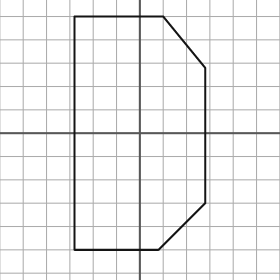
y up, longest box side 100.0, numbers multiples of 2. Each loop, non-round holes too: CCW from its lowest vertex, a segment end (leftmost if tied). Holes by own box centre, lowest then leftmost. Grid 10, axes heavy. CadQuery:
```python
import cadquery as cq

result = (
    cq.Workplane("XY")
    .moveTo(-28.0, -50.0)
    .lineTo(8.0, -50.0)
    .lineTo(28.0, -30.0)
    .lineTo(28.0, 28.0)
    .lineTo(10.0, 50.0)
    .lineTo(-28.0, 50.0)
    .close()
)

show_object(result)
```